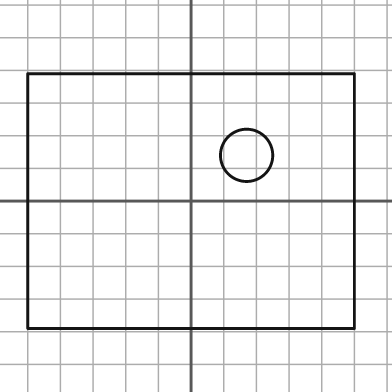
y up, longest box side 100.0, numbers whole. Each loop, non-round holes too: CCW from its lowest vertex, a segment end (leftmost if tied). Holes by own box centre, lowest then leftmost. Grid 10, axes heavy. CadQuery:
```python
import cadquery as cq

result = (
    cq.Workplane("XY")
    .moveTo(-50.0, -39.0)
    .lineTo(50.0, -39.0)
    .lineTo(50.0, 39.0)
    .lineTo(-50.0, 39.0)
    .close()
    .moveTo(17.0, 14.0)
    .circle(8.0)
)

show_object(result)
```